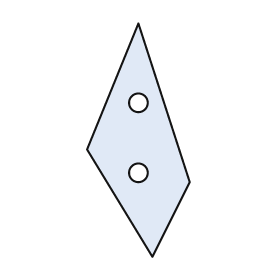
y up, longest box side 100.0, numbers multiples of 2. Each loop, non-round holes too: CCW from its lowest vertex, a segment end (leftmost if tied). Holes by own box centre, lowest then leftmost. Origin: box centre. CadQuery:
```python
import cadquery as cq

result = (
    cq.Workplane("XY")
    .moveTo(6.0, -50.0)
    .lineTo(22.0, -18.0)
    .lineTo(0.0, 50.0)
    .lineTo(-22.0, -4.0)
    .close()
    .moveTo(0.0, -14.0)
    .circle(4.0)
    .moveTo(0.0, 16.0)
    .circle(4.0)
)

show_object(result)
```